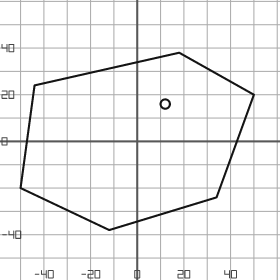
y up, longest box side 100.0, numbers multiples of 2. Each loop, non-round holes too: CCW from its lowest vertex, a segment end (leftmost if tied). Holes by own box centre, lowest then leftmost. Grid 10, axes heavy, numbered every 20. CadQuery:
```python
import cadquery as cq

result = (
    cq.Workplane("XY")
    .moveTo(-12.0, -38.0)
    .lineTo(34.0, -24.0)
    .lineTo(50.0, 20.0)
    .lineTo(18.0, 38.0)
    .lineTo(-44.0, 24.0)
    .lineTo(-50.0, -20.0)
    .close()
    .moveTo(12.0, 16.0)
    .circle(2.0)
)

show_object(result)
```